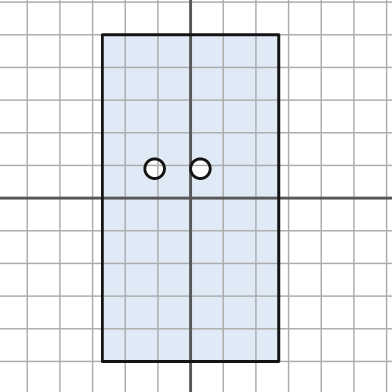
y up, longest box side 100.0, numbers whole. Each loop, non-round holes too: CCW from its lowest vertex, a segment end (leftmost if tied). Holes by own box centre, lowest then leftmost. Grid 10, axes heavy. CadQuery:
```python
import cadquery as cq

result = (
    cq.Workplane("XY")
    .moveTo(-27.0, -50.0)
    .lineTo(27.0, -50.0)
    .lineTo(27.0, 50.0)
    .lineTo(-27.0, 50.0)
    .close()
    .moveTo(-11.0, 9.0)
    .circle(3.0)
    .moveTo(3.0, 9.0)
    .circle(3.0)
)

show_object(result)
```